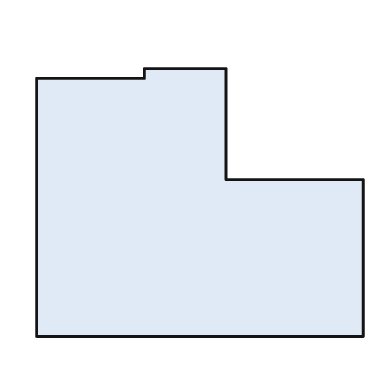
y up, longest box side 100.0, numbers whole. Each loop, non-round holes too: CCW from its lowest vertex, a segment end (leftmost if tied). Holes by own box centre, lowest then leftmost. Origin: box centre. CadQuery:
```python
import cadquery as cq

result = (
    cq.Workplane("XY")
    .moveTo(-50.0, -41.0)
    .lineTo(50.0, -41.0)
    .lineTo(50.0, 7.0)
    .lineTo(8.0, 7.0)
    .lineTo(8.0, 41.0)
    .lineTo(-17.0, 41.0)
    .lineTo(-17.0, 38.0)
    .lineTo(-50.0, 38.0)
    .close()
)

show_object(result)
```